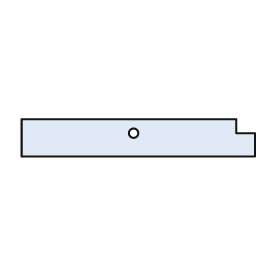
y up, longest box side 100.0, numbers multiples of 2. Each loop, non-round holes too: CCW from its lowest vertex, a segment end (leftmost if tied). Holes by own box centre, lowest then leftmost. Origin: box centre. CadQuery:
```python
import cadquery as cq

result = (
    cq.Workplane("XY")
    .moveTo(-50.0, -8.0)
    .lineTo(50.0, -8.0)
    .lineTo(50.0, 2.0)
    .lineTo(42.0, 2.0)
    .lineTo(42.0, 8.0)
    .lineTo(-50.0, 8.0)
    .close()
    .moveTo(-2.0, 2.0)
    .circle(2.0)
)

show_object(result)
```